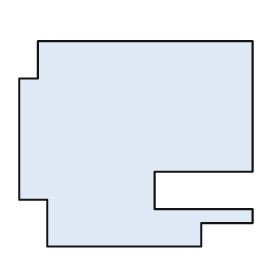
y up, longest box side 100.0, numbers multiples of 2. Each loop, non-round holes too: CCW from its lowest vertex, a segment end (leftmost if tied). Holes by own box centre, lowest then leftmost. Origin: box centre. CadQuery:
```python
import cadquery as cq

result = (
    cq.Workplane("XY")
    .moveTo(-38.0, -44.0)
    .lineTo(28.0, -44.0)
    .lineTo(28.0, -34.0)
    .lineTo(50.0, -34.0)
    .lineTo(50.0, -28.0)
    .lineTo(8.0, -28.0)
    .lineTo(8.0, -12.0)
    .lineTo(50.0, -12.0)
    .lineTo(50.0, 44.0)
    .lineTo(-42.0, 44.0)
    .lineTo(-42.0, 28.0)
    .lineTo(-50.0, 28.0)
    .lineTo(-50.0, -24.0)
    .lineTo(-38.0, -24.0)
    .close()
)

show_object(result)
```